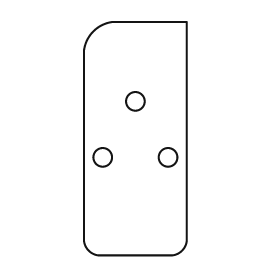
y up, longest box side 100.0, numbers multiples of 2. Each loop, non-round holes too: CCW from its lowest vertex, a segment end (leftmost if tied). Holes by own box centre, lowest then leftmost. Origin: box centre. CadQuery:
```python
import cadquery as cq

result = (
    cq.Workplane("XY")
    .moveTo(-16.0, -50.0)
    .lineTo(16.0, -50.0)
    .threePointArc((20.0, -48.0), (22.0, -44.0))
    .lineTo(22.0, 50.0)
    .lineTo(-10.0, 50.0)
    .threePointArc((-18.0, 46.0), (-22.0, 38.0))
    .lineTo(-22.0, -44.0)
    .threePointArc((-20.0, -48.0), (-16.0, -50.0))
    .close()
    .moveTo(-14.0, -8.0)
    .circle(4.0)
    .moveTo(14.0, -8.0)
    .circle(4.0)
    .moveTo(0.0, 16.0)
    .circle(4.0)
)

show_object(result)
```